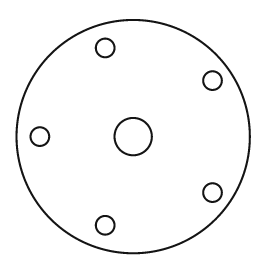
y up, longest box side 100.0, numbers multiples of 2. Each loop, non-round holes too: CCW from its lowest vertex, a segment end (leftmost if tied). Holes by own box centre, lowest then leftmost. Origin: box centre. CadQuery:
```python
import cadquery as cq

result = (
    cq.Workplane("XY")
    .moveTo(0.0, 0.0)
    .circle(50.0)
    .moveTo(-12.0, -38.0)
    .circle(4.0)
    .moveTo(34.0, -24.0)
    .circle(4.0)
    .moveTo(-40.0, 0.0)
    .circle(4.0)
    .moveTo(0.0, 0.0)
    .circle(8.0)
    .moveTo(34.0, 24.0)
    .circle(4.0)
    .moveTo(-12.0, 38.0)
    .circle(4.0)
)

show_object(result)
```